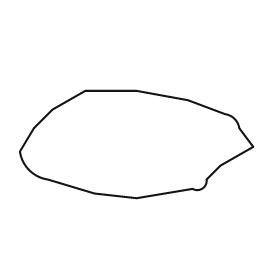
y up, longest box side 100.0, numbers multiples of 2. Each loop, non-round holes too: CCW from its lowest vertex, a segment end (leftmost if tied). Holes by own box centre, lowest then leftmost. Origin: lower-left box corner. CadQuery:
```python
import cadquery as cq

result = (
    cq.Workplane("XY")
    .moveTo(50.0, 0.0)
    .lineTo(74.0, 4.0)
    .threePointArc((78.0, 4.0), (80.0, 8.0))
    .lineTo(86.0, 14.0)
    .lineTo(100.0, 22.0)
    .lineTo(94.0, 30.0)
    .threePointArc((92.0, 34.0), (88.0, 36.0))
    .lineTo(72.0, 42.0)
    .lineTo(50.0, 46.0)
    .lineTo(28.0, 46.0)
    .lineTo(14.0, 38.0)
    .lineTo(6.0, 30.0)
    .lineTo(0.0, 20.0)
    .threePointArc((4.0, 12.0), (12.0, 8.0))
    .lineTo(32.0, 2.0)
    .close()
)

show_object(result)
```